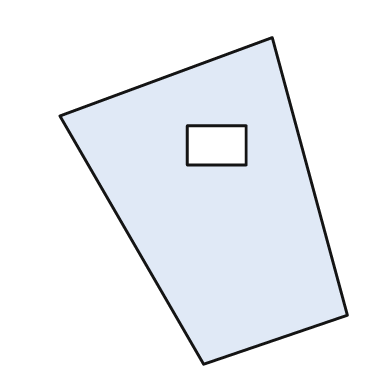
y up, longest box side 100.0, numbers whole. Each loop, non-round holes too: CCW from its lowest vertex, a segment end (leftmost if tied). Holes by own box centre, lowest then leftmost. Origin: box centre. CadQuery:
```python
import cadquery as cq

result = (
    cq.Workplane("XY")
    .moveTo(0.0, -50.0)
    .lineTo(44.0, -35.0)
    .lineTo(21.0, 50.0)
    .lineTo(-44.0, 26.0)
    .close()
    .moveTo(-5.0, 11.0)
    .lineTo(13.0, 11.0)
    .lineTo(13.0, 23.0)
    .lineTo(-5.0, 23.0)
    .close()
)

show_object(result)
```